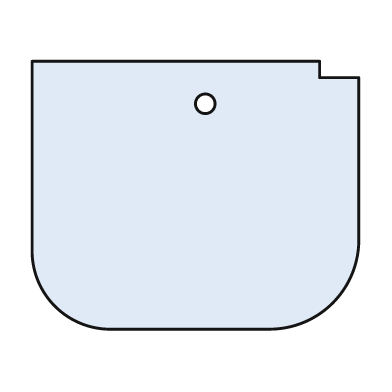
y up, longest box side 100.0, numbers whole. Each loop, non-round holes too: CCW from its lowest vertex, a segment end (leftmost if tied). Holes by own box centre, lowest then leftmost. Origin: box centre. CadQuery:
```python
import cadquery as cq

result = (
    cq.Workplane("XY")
    .moveTo(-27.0, -41.0)
    .lineTo(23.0, -41.0)
    .threePointArc((42.0, -33.0), (50.0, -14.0))
    .lineTo(50.0, 36.0)
    .lineTo(38.0, 36.0)
    .lineTo(38.0, 41.0)
    .lineTo(-50.0, 41.0)
    .lineTo(-50.0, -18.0)
    .threePointArc((-43.0, -34.0), (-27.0, -41.0))
    .close()
    .moveTo(3.0, 28.0)
    .circle(3.0)
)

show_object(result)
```